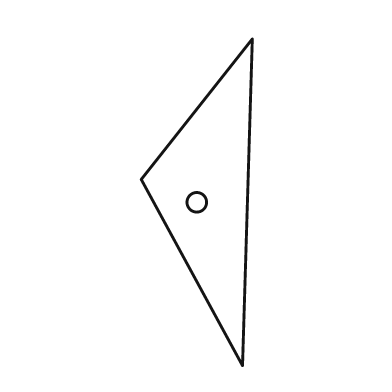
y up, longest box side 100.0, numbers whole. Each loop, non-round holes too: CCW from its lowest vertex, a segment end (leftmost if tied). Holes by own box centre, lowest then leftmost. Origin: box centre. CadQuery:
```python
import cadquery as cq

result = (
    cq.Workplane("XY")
    .moveTo(14.0, -50.0)
    .lineTo(17.0, 50.0)
    .lineTo(-17.0, 7.0)
    .close()
    .moveTo(0.0, 0.0)
    .circle(3.0)
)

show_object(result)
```